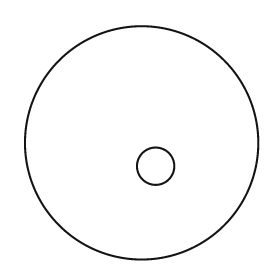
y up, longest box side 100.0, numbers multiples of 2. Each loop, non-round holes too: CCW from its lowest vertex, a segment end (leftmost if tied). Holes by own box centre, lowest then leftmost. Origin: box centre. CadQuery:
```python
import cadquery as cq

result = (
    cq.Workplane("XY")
    .moveTo(0.0, 0.0)
    .circle(50.0)
    .moveTo(6.0, -10.0)
    .circle(8.0)
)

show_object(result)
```